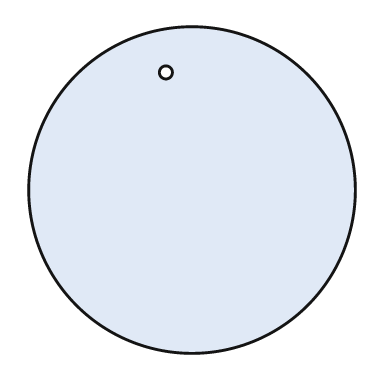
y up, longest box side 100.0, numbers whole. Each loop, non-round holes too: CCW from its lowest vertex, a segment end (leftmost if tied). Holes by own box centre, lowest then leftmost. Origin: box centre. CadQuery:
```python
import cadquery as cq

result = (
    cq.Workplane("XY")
    .moveTo(0.0, 0.0)
    .circle(50.0)
    .moveTo(-8.0, 36.0)
    .circle(2.0)
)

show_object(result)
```